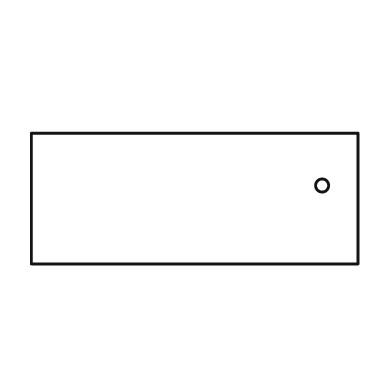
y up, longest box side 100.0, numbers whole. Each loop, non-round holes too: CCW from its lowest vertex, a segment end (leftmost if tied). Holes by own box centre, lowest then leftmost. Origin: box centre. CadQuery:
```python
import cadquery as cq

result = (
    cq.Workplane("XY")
    .moveTo(-50.0, -20.0)
    .lineTo(50.0, -20.0)
    .lineTo(50.0, 20.0)
    .lineTo(-50.0, 20.0)
    .close()
    .moveTo(39.0, 4.0)
    .circle(2.0)
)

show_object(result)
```